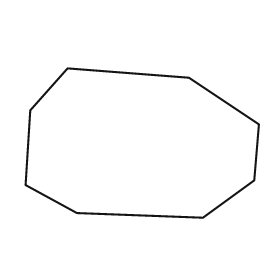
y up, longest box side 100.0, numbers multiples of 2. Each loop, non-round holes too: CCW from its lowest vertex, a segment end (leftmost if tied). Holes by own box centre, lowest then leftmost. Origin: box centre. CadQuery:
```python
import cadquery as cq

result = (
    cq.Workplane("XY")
    .moveTo(26.0, -32.0)
    .lineTo(48.0, -16.0)
    .lineTo(50.0, 8.0)
    .lineTo(20.0, 28.0)
    .lineTo(-32.0, 32.0)
    .lineTo(-48.0, 14.0)
    .lineTo(-50.0, -18.0)
    .lineTo(-28.0, -30.0)
    .close()
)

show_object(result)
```